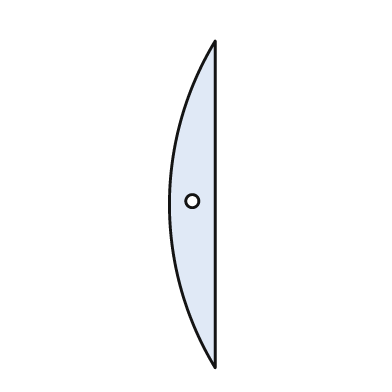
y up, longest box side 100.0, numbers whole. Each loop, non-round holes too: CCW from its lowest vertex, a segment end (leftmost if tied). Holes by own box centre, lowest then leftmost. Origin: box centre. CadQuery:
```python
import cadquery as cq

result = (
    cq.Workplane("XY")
    .moveTo(7.0, -50.0)
    .lineTo(7.0, 50.0)
    .threePointArc((-7.0, 0.0), (7.0, -50.0))
    .close()
    .moveTo(0.0, 1.0)
    .circle(2.0)
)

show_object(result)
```